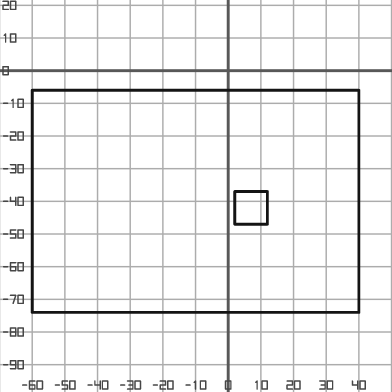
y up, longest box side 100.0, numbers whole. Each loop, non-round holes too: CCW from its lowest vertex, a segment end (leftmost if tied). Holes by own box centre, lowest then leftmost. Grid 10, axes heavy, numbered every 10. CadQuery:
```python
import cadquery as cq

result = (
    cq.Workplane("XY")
    .moveTo(-60.0, -74.0)
    .lineTo(40.0, -74.0)
    .lineTo(40.0, -6.0)
    .lineTo(-60.0, -6.0)
    .close()
    .moveTo(2.0, -47.0)
    .lineTo(12.0, -47.0)
    .lineTo(12.0, -37.0)
    .lineTo(2.0, -37.0)
    .close()
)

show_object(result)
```